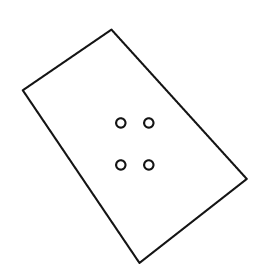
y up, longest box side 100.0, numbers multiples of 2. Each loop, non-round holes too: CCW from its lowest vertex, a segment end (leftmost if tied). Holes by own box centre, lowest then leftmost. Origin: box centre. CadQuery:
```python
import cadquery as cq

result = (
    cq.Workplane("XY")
    .moveTo(2.0, -50.0)
    .lineTo(48.0, -14.0)
    .lineTo(-10.0, 50.0)
    .lineTo(-48.0, 24.0)
    .close()
    .moveTo(-6.0, -8.0)
    .circle(2.0)
    .moveTo(6.0, -8.0)
    .circle(2.0)
    .moveTo(-6.0, 10.0)
    .circle(2.0)
    .moveTo(6.0, 10.0)
    .circle(2.0)
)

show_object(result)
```